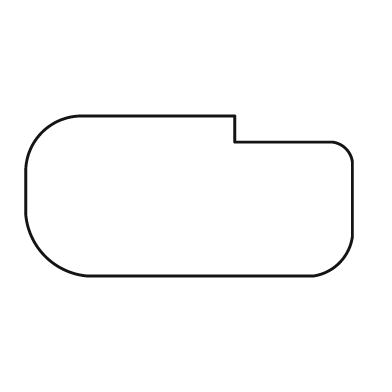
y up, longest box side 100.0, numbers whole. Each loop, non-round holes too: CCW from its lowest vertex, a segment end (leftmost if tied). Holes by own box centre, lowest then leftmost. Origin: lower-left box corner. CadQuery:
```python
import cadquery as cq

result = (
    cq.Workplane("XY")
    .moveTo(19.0, 0.0)
    .lineTo(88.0, 0.0)
    .threePointArc((96.0, 4.0), (100.0, 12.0))
    .lineTo(100.0, 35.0)
    .threePointArc((98.0, 39.0), (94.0, 41.0))
    .lineTo(64.0, 41.0)
    .lineTo(64.0, 49.0)
    .lineTo(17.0, 49.0)
    .threePointArc((5.0, 44.0), (0.0, 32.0))
    .lineTo(0.0, 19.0)
    .threePointArc((6.0, 6.0), (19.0, 0.0))
    .close()
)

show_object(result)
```